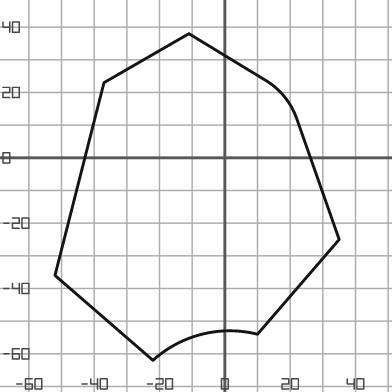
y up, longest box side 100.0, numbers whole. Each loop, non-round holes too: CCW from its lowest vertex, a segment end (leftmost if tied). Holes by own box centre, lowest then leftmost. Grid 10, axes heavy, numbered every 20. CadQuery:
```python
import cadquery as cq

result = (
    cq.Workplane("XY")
    .moveTo(-22.0, -62.0)
    .threePointArc((-7.0, -54.0), (10.0, -54.0))
    .lineTo(35.0, -25.0)
    .lineTo(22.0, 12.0)
    .threePointArc((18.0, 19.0), (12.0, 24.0))
    .lineTo(-11.0, 38.0)
    .lineTo(-37.0, 23.0)
    .lineTo(-52.0, -36.0)
    .close()
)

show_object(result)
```